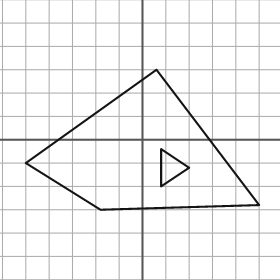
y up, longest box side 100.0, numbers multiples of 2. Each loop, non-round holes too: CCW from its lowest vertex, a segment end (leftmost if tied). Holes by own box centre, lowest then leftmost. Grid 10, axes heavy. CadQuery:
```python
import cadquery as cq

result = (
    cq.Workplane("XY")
    .moveTo(-18.0, -30.0)
    .lineTo(50.0, -28.0)
    .lineTo(6.0, 30.0)
    .lineTo(-50.0, -10.0)
    .close()
    .moveTo(8.0, -20.0)
    .lineTo(20.0, -12.0)
    .lineTo(8.0, -4.0)
    .close()
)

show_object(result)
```